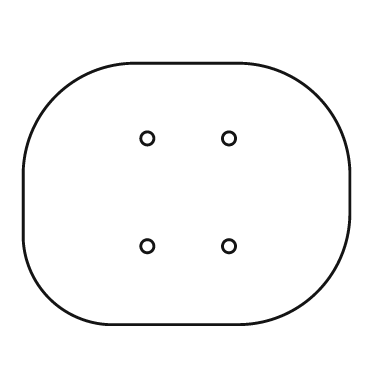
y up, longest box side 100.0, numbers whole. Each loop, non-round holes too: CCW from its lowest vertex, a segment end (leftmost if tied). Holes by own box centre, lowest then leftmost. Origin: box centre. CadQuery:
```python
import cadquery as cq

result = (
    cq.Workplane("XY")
    .moveTo(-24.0, -40.0)
    .lineTo(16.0, -40.0)
    .threePointArc((40.0, -30.0), (50.0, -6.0))
    .lineTo(50.0, 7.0)
    .threePointArc((40.0, 30.0), (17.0, 40.0))
    .lineTo(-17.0, 40.0)
    .threePointArc((-40.0, 30.0), (-50.0, 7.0))
    .lineTo(-50.0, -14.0)
    .threePointArc((-42.0, -32.0), (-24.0, -40.0))
    .close()
    .moveTo(-12.0, -16.0)
    .circle(2.0)
    .moveTo(13.0, -16.0)
    .circle(2.0)
    .moveTo(-12.0, 17.0)
    .circle(2.0)
    .moveTo(13.0, 17.0)
    .circle(2.0)
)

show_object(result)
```